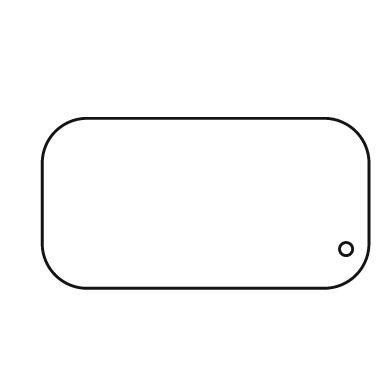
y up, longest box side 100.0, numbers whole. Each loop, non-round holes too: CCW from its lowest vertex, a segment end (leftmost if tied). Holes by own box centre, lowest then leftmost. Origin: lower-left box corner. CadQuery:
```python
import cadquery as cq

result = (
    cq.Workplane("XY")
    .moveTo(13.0, 0.0)
    .lineTo(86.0, 0.0)
    .threePointArc((96.0, 4.0), (100.0, 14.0))
    .lineTo(100.0, 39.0)
    .threePointArc((96.0, 48.0), (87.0, 52.0))
    .lineTo(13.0, 52.0)
    .threePointArc((4.0, 48.0), (0.0, 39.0))
    .lineTo(0.0, 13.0)
    .threePointArc((4.0, 4.0), (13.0, 0.0))
    .close()
    .moveTo(93.0, 12.0)
    .circle(2.0)
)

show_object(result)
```